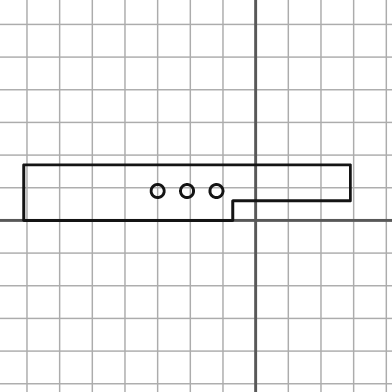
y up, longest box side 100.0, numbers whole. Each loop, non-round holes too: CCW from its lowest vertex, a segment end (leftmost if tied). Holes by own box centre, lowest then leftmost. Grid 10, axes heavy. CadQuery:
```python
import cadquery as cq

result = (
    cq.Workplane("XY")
    .moveTo(-71.0, 0.0)
    .lineTo(-7.0, 0.0)
    .lineTo(-7.0, 6.0)
    .lineTo(29.0, 6.0)
    .lineTo(29.0, 17.0)
    .lineTo(-71.0, 17.0)
    .close()
    .moveTo(-30.0, 9.0)
    .circle(2.0)
    .moveTo(-21.0, 9.0)
    .circle(2.0)
    .moveTo(-12.0, 9.0)
    .circle(2.0)
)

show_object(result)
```